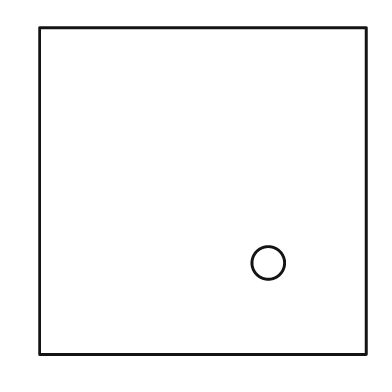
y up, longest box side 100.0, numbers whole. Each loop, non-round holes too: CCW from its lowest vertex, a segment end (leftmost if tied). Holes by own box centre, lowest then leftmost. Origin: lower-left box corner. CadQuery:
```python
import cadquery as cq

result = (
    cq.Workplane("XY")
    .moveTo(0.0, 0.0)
    .lineTo(100.0, 0.0)
    .lineTo(100.0, 100.0)
    .lineTo(0.0, 100.0)
    .close()
    .moveTo(70.0, 28.0)
    .circle(5.0)
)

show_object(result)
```